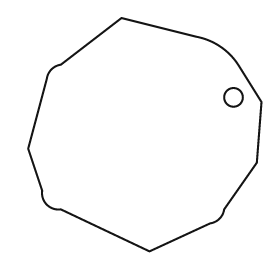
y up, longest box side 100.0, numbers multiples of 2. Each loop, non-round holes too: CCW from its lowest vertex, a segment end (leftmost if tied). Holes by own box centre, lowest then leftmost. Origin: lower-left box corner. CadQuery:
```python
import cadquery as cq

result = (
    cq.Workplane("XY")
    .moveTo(52.0, 0.0)
    .lineTo(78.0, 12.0)
    .threePointArc((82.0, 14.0), (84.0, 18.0))
    .lineTo(98.0, 38.0)
    .lineTo(100.0, 64.0)
    .lineTo(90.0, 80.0)
    .threePointArc((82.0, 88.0), (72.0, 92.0))
    .lineTo(40.0, 100.0)
    .lineTo(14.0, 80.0)
    .threePointArc((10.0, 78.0), (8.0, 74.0))
    .lineTo(0.0, 44.0)
    .lineTo(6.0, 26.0)
    .threePointArc((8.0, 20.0), (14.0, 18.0))
    .close()
    .moveTo(88.0, 66.0)
    .circle(4.0)
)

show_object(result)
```